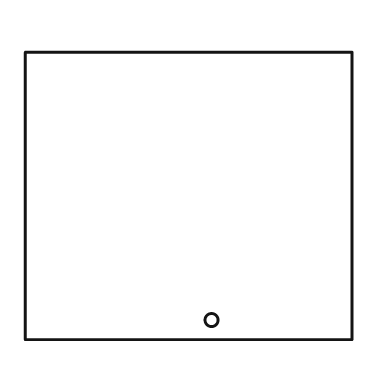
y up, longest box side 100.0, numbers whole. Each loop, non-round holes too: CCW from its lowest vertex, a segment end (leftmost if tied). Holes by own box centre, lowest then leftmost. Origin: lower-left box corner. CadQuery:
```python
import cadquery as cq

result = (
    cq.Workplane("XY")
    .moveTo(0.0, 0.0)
    .lineTo(100.0, 0.0)
    .lineTo(100.0, 88.0)
    .lineTo(0.0, 88.0)
    .close()
    .moveTo(57.0, 6.0)
    .circle(2.0)
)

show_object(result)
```